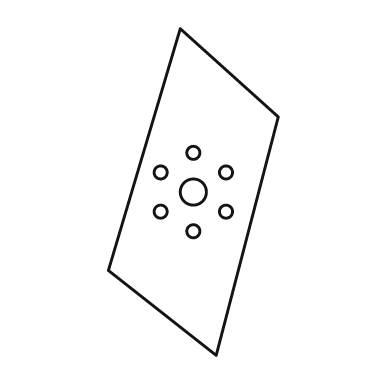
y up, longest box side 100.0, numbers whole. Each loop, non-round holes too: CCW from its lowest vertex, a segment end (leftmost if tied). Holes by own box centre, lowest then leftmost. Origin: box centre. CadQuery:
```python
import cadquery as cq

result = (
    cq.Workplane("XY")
    .moveTo(7.0, -50.0)
    .lineTo(26.0, 23.0)
    .lineTo(-4.0, 50.0)
    .lineTo(-26.0, -24.0)
    .close()
    .moveTo(0.0, -12.0)
    .circle(2.0)
    .moveTo(-10.0, -6.0)
    .circle(2.0)
    .moveTo(10.0, -6.0)
    .circle(2.0)
    .moveTo(0.0, 0.0)
    .circle(4.0)
    .moveTo(-10.0, 6.0)
    .circle(2.0)
    .moveTo(10.0, 6.0)
    .circle(2.0)
    .moveTo(0.0, 12.0)
    .circle(2.0)
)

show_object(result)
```